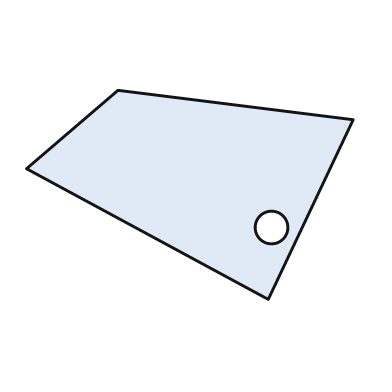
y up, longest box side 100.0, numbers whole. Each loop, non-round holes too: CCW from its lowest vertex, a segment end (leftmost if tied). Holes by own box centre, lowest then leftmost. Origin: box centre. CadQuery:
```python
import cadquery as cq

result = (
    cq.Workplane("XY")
    .moveTo(24.0, -32.0)
    .lineTo(50.0, 23.0)
    .lineTo(-22.0, 32.0)
    .lineTo(-50.0, 8.0)
    .close()
    .moveTo(25.0, -10.0)
    .circle(5.0)
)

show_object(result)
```